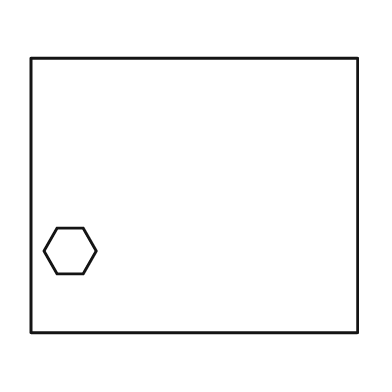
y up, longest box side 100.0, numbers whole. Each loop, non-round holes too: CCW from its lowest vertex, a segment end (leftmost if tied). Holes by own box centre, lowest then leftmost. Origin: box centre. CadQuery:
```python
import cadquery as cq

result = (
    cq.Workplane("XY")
    .moveTo(-50.0, -42.0)
    .lineTo(50.0, -42.0)
    .lineTo(50.0, 42.0)
    .lineTo(-50.0, 42.0)
    .close()
    .moveTo(-42.0, -24.0)
    .lineTo(-34.0, -24.0)
    .lineTo(-30.0, -17.0)
    .lineTo(-34.0, -10.0)
    .lineTo(-42.0, -10.0)
    .lineTo(-46.0, -17.0)
    .close()
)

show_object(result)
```